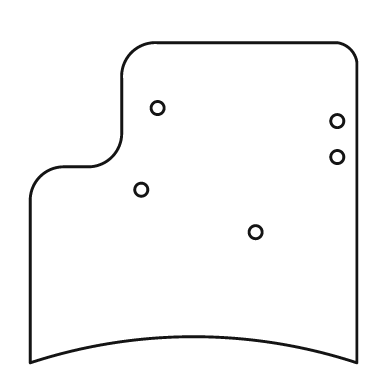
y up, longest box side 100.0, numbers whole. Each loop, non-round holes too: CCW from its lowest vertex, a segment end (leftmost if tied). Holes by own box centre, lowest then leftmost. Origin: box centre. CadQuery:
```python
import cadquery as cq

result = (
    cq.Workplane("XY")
    .moveTo(-50.0, -49.0)
    .threePointArc((0.0, -41.0), (50.0, -49.0))
    .lineTo(50.0, 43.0)
    .threePointArc((48.0, 47.0), (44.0, 49.0))
    .lineTo(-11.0, 49.0)
    .threePointArc((-19.0, 46.0), (-22.0, 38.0))
    .lineTo(-22.0, 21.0)
    .threePointArc((-25.0, 14.0), (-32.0, 11.0))
    .lineTo(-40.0, 11.0)
    .threePointArc((-47.0, 8.0), (-50.0, 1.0))
    .close()
    .moveTo(19.0, -9.0)
    .circle(2.0)
    .moveTo(-16.0, 4.0)
    .circle(2.0)
    .moveTo(44.0, 14.0)
    .circle(2.0)
    .moveTo(44.0, 25.0)
    .circle(2.0)
    .moveTo(-11.0, 29.0)
    .circle(2.0)
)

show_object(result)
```